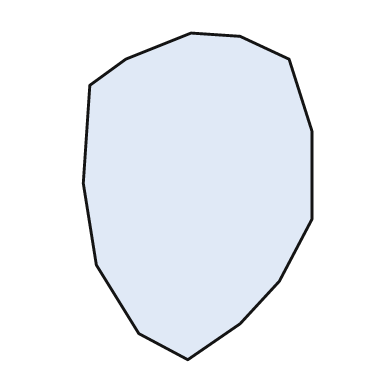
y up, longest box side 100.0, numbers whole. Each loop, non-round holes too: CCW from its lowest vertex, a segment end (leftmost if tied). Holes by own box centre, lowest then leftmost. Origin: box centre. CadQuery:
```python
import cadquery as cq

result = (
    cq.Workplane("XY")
    .moveTo(-3.0, -50.0)
    .lineTo(13.0, -39.0)
    .lineTo(25.0, -26.0)
    .lineTo(35.0, -7.0)
    .lineTo(35.0, 20.0)
    .lineTo(28.0, 42.0)
    .lineTo(13.0, 49.0)
    .lineTo(-2.0, 50.0)
    .lineTo(-22.0, 42.0)
    .lineTo(-33.0, 34.0)
    .lineTo(-35.0, 4.0)
    .lineTo(-31.0, -21.0)
    .lineTo(-18.0, -42.0)
    .close()
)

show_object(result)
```